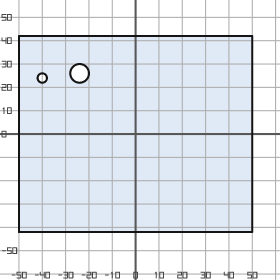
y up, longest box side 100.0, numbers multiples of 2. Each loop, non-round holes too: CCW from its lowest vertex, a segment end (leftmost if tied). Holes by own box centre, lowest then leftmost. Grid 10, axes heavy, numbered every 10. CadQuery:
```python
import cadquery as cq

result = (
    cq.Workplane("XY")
    .moveTo(-50.0, -42.0)
    .lineTo(50.0, -42.0)
    .lineTo(50.0, 42.0)
    .lineTo(-50.0, 42.0)
    .close()
    .moveTo(-40.0, 24.0)
    .circle(2.0)
    .moveTo(-24.0, 26.0)
    .circle(4.0)
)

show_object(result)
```